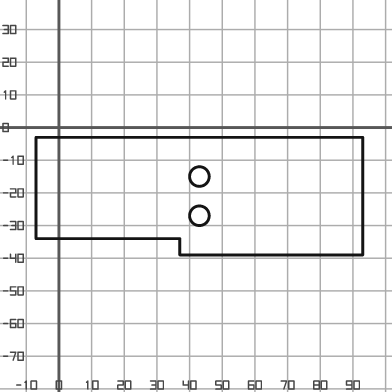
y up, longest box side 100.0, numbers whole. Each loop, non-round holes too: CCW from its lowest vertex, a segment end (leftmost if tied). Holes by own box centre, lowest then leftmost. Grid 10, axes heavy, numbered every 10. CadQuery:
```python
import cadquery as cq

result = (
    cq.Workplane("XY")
    .moveTo(37.0, -39.0)
    .lineTo(93.0, -39.0)
    .lineTo(93.0, -3.0)
    .lineTo(-7.0, -3.0)
    .lineTo(-7.0, -34.0)
    .lineTo(37.0, -34.0)
    .close()
    .moveTo(43.0, -27.0)
    .circle(3.0)
    .moveTo(43.0, -15.0)
    .circle(3.0)
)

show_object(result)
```